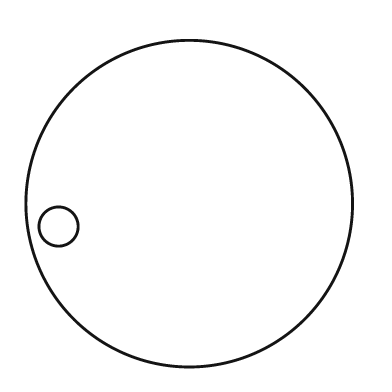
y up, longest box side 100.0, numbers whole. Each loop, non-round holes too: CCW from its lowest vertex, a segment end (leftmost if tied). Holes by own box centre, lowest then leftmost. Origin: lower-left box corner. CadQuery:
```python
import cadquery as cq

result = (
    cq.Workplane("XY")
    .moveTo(50.0, 50.0)
    .circle(50.0)
    .moveTo(10.0, 43.0)
    .circle(6.0)
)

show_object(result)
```